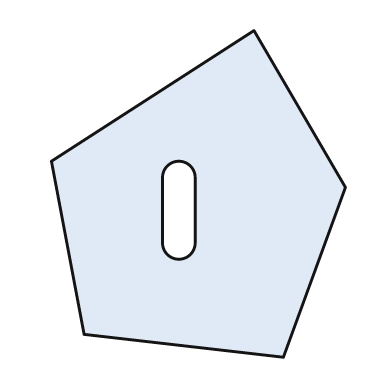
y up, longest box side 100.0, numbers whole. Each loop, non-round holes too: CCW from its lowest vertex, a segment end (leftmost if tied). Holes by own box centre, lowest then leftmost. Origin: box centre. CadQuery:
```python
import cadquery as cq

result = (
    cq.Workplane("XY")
    .moveTo(26.0, -50.0)
    .lineTo(45.0, 2.0)
    .lineTo(17.0, 50.0)
    .lineTo(-45.0, 10.0)
    .lineTo(-35.0, -43.0)
    .close()
    .moveTo(-11.0, -15.0)
    .threePointArc((-6.0, -20.0), (-1.0, -15.0))
    .lineTo(-1.0, 5.0)
    .threePointArc((-6.0, 10.0), (-11.0, 5.0))
    .close()
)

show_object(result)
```